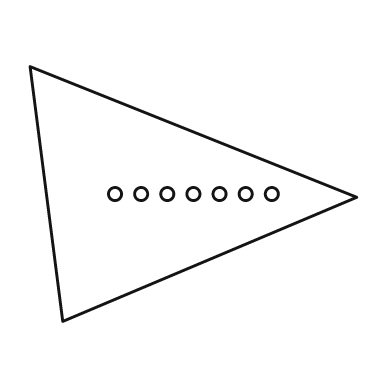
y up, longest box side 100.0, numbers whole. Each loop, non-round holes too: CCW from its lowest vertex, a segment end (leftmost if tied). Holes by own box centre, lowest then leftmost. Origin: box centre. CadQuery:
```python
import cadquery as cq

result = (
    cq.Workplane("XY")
    .moveTo(-40.0, -39.0)
    .lineTo(50.0, -1.0)
    .lineTo(-50.0, 39.0)
    .close()
    .moveTo(-24.0, 0.0)
    .circle(2.0)
    .moveTo(-16.0, 0.0)
    .circle(2.0)
    .moveTo(-8.0, 0.0)
    .circle(2.0)
    .moveTo(0.0, 0.0)
    .circle(2.0)
    .moveTo(8.0, 0.0)
    .circle(2.0)
    .moveTo(16.0, 0.0)
    .circle(2.0)
    .moveTo(24.0, 0.0)
    .circle(2.0)
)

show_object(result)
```